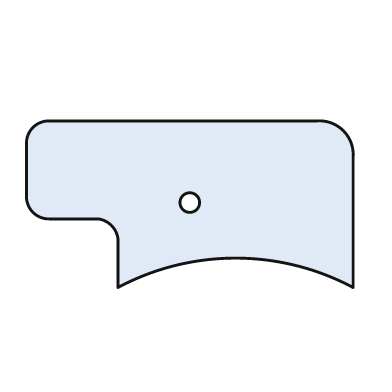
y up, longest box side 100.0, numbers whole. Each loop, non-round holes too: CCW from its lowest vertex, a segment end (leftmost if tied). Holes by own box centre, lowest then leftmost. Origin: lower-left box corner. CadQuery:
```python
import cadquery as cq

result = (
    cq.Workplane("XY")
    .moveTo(28.0, 0.0)
    .threePointArc((64.0, 9.0), (100.0, 0.0))
    .lineTo(100.0, 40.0)
    .threePointArc((97.0, 48.0), (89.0, 51.0))
    .lineTo(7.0, 51.0)
    .threePointArc((2.0, 49.0), (0.0, 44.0))
    .lineTo(0.0, 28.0)
    .threePointArc((2.0, 23.0), (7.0, 21.0))
    .lineTo(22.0, 21.0)
    .threePointArc((26.0, 19.0), (28.0, 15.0))
    .close()
    .moveTo(50.0, 26.0)
    .circle(3.0)
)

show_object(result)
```